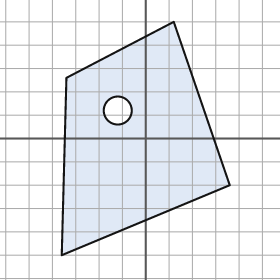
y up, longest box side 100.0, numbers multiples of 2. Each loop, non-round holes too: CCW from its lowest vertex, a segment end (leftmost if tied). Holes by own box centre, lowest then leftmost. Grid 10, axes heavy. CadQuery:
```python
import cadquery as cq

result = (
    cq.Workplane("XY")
    .moveTo(-36.0, -50.0)
    .lineTo(36.0, -20.0)
    .lineTo(12.0, 50.0)
    .lineTo(-34.0, 26.0)
    .close()
    .moveTo(-12.0, 12.0)
    .circle(6.0)
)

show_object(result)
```